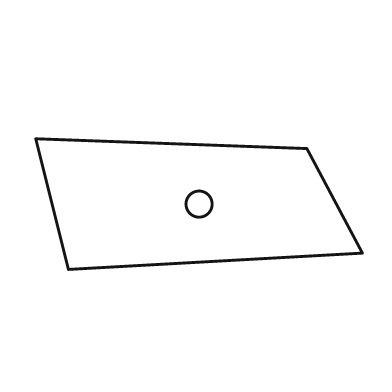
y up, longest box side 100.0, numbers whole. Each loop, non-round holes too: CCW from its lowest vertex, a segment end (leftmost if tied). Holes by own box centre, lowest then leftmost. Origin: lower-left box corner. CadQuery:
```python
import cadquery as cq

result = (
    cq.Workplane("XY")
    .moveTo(10.0, 0.0)
    .lineTo(100.0, 5.0)
    .lineTo(83.0, 37.0)
    .lineTo(0.0, 40.0)
    .close()
    .moveTo(50.0, 20.0)
    .circle(4.0)
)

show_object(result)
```